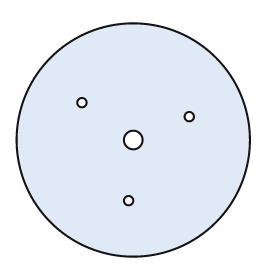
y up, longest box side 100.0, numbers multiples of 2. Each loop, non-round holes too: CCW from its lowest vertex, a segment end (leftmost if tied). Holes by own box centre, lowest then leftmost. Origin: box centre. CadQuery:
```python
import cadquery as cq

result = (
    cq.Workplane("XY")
    .moveTo(0.0, 0.0)
    .circle(50.0)
    .moveTo(-2.0, -26.0)
    .circle(2.0)
    .moveTo(0.0, 0.0)
    .circle(4.0)
    .moveTo(24.0, 10.0)
    .circle(2.0)
    .moveTo(-22.0, 16.0)
    .circle(2.0)
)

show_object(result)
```